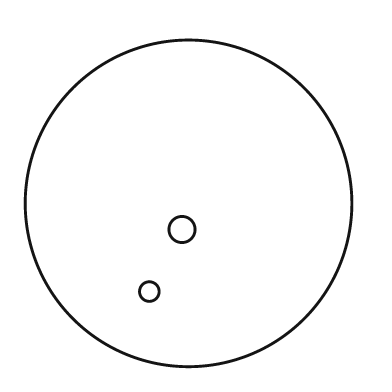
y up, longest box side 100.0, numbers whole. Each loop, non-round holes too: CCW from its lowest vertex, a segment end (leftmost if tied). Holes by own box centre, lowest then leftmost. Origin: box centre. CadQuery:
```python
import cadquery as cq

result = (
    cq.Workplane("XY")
    .moveTo(0.0, 0.0)
    .circle(50.0)
    .moveTo(-12.0, -27.0)
    .circle(3.0)
    .moveTo(-2.0, -8.0)
    .circle(4.0)
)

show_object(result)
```